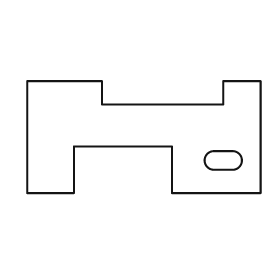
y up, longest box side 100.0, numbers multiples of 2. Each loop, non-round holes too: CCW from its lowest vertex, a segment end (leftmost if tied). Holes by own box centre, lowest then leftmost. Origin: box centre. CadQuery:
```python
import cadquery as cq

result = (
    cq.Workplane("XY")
    .moveTo(-50.0, -24.0)
    .lineTo(-30.0, -24.0)
    .lineTo(-30.0, -4.0)
    .lineTo(12.0, -4.0)
    .lineTo(12.0, -24.0)
    .lineTo(50.0, -24.0)
    .lineTo(50.0, 24.0)
    .lineTo(34.0, 24.0)
    .lineTo(34.0, 14.0)
    .lineTo(-18.0, 14.0)
    .lineTo(-18.0, 24.0)
    .lineTo(-50.0, 24.0)
    .close()
    .moveTo(30.0, -14.0)
    .lineTo(38.0, -14.0)
    .threePointArc((42.0, -10.0), (38.0, -6.0))
    .lineTo(30.0, -6.0)
    .threePointArc((26.0, -10.0), (30.0, -14.0))
    .close()
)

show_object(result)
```